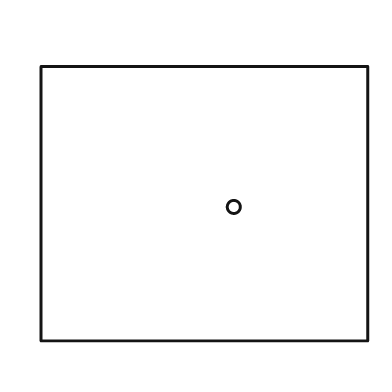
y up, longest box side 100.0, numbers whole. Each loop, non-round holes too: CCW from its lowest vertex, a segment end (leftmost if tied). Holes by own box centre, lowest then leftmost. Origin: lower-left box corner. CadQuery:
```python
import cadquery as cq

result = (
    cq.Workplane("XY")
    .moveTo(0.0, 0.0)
    .lineTo(100.0, 0.0)
    .lineTo(100.0, 84.0)
    .lineTo(0.0, 84.0)
    .close()
    .moveTo(59.0, 41.0)
    .circle(2.0)
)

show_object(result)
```